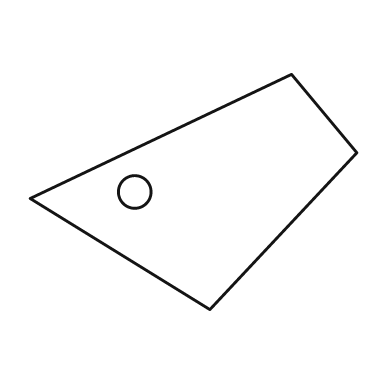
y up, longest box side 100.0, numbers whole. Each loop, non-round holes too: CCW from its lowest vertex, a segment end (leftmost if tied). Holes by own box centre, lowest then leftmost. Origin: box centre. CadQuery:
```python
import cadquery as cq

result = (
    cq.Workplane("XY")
    .moveTo(5.0, -36.0)
    .lineTo(50.0, 12.0)
    .lineTo(30.0, 36.0)
    .lineTo(-50.0, -2.0)
    .close()
    .moveTo(-18.0, 0.0)
    .circle(5.0)
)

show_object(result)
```